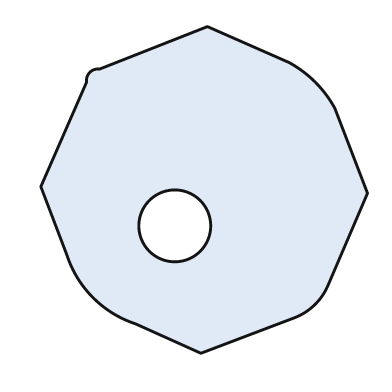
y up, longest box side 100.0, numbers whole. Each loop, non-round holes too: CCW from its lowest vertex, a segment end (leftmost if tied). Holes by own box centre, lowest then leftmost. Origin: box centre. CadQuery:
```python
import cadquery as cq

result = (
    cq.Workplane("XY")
    .moveTo(-1.0, -50.0)
    .lineTo(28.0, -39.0)
    .threePointArc((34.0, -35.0), (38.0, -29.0))
    .lineTo(50.0, -1.0)
    .lineTo(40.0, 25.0)
    .threePointArc((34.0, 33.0), (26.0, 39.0))
    .lineTo(1.0, 50.0)
    .lineTo(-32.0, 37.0)
    .threePointArc((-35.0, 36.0), (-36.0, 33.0))
    .lineTo(-50.0, 1.0)
    .lineTo(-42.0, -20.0)
    .threePointArc((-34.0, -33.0), (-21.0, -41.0))
    .close()
    .moveTo(-9.0, -11.0)
    .circle(11.0)
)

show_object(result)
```